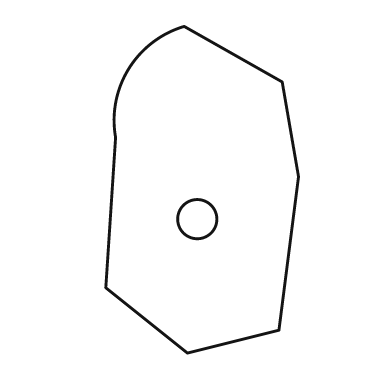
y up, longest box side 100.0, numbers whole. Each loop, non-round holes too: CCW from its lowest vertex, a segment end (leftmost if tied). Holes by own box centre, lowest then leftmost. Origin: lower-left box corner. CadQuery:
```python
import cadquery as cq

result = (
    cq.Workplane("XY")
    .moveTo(25.0, 0.0)
    .lineTo(53.0, 7.0)
    .lineTo(59.0, 54.0)
    .lineTo(54.0, 83.0)
    .lineTo(24.0, 100.0)
    .threePointArc((7.0, 87.0), (3.0, 66.0))
    .lineTo(0.0, 20.0)
    .close()
    .moveTo(28.0, 41.0)
    .circle(6.0)
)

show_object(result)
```